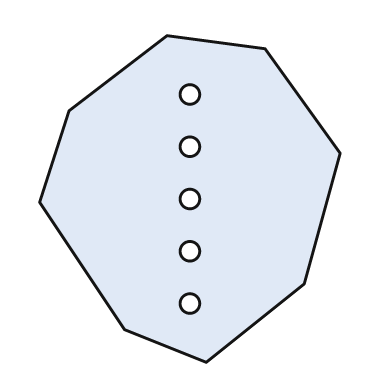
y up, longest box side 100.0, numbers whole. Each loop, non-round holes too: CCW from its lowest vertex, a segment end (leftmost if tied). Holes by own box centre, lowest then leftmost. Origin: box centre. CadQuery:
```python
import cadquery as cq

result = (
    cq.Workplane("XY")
    .moveTo(5.0, -50.0)
    .lineTo(35.0, -26.0)
    .lineTo(46.0, 14.0)
    .lineTo(23.0, 46.0)
    .lineTo(-7.0, 50.0)
    .lineTo(-37.0, 27.0)
    .lineTo(-46.0, -1.0)
    .lineTo(-20.0, -40.0)
    .close()
    .moveTo(0.0, -32.0)
    .circle(3.0)
    .moveTo(0.0, -16.0)
    .circle(3.0)
    .moveTo(0.0, 0.0)
    .circle(3.0)
    .moveTo(0.0, 16.0)
    .circle(3.0)
    .moveTo(0.0, 32.0)
    .circle(3.0)
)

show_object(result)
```